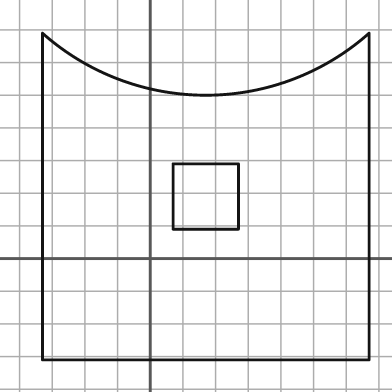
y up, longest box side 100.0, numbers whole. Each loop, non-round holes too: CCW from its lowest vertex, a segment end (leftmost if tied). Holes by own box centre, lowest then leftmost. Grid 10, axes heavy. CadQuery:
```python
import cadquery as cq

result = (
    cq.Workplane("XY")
    .moveTo(-33.0, -31.0)
    .lineTo(67.0, -31.0)
    .lineTo(67.0, 69.0)
    .threePointArc((17.0, 50.0), (-33.0, 69.0))
    .close()
    .moveTo(7.0, 9.0)
    .lineTo(27.0, 9.0)
    .lineTo(27.0, 29.0)
    .lineTo(7.0, 29.0)
    .close()
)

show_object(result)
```